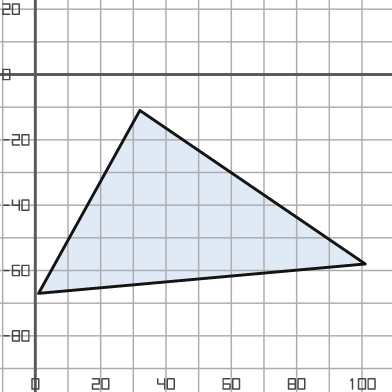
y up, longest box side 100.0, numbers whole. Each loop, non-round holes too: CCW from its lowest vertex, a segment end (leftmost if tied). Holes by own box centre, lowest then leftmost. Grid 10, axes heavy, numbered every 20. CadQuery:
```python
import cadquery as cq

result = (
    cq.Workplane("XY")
    .moveTo(1.0, -67.0)
    .lineTo(101.0, -58.0)
    .lineTo(32.0, -11.0)
    .close()
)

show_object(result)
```